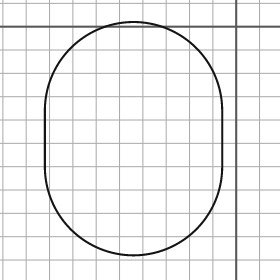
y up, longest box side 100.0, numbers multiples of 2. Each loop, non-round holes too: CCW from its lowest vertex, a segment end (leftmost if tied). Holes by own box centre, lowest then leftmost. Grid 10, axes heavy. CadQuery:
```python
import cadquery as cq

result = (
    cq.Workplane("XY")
    .moveTo(-82.0, -60.0)
    .threePointArc((-44.0, -98.0), (-6.0, -60.0))
    .lineTo(-6.0, -36.0)
    .threePointArc((-44.0, 2.0), (-82.0, -36.0))
    .close()
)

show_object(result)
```